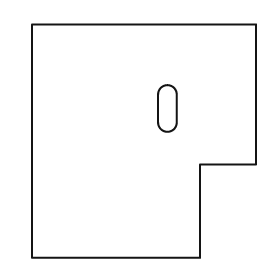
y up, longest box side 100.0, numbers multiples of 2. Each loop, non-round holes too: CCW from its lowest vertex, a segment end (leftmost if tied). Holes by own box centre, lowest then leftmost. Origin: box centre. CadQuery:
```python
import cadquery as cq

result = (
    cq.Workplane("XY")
    .moveTo(-48.0, -50.0)
    .lineTo(24.0, -50.0)
    .lineTo(24.0, -10.0)
    .lineTo(48.0, -10.0)
    .lineTo(48.0, 50.0)
    .lineTo(-48.0, 50.0)
    .close()
    .moveTo(6.0, 8.0)
    .threePointArc((10.0, 4.0), (14.0, 8.0))
    .lineTo(14.0, 20.0)
    .threePointArc((10.0, 24.0), (6.0, 20.0))
    .close()
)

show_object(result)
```